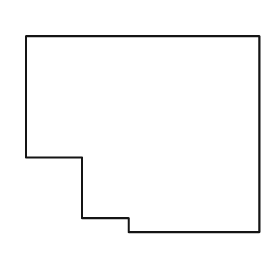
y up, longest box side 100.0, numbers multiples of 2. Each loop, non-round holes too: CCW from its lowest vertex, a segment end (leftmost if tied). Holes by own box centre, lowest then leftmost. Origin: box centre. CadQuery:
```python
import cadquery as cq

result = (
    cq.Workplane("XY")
    .moveTo(-6.0, -42.0)
    .lineTo(50.0, -42.0)
    .lineTo(50.0, 42.0)
    .lineTo(-50.0, 42.0)
    .lineTo(-50.0, -10.0)
    .lineTo(-26.0, -10.0)
    .lineTo(-26.0, -36.0)
    .lineTo(-6.0, -36.0)
    .close()
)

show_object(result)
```